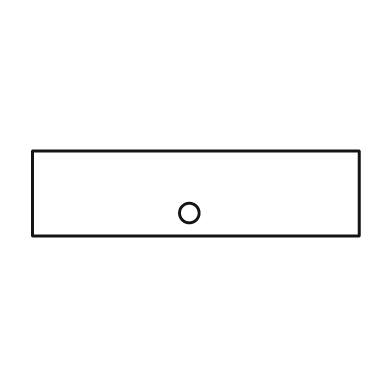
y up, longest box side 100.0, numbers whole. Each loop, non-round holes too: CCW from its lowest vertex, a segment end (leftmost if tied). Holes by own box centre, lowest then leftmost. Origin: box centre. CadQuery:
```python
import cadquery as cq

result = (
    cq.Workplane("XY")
    .moveTo(-50.0, -13.0)
    .lineTo(50.0, -13.0)
    .lineTo(50.0, 13.0)
    .lineTo(-50.0, 13.0)
    .close()
    .moveTo(-2.0, -6.0)
    .circle(3.0)
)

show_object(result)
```